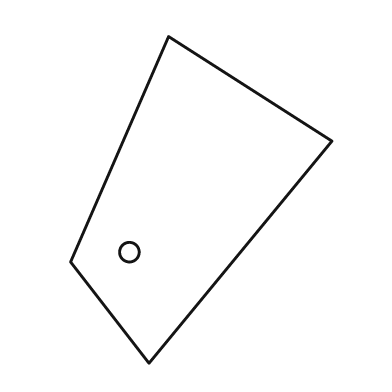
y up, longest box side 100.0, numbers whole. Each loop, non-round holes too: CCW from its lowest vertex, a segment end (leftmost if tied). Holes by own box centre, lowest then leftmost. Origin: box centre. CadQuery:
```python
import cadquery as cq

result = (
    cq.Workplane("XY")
    .moveTo(-16.0, -50.0)
    .lineTo(40.0, 18.0)
    .lineTo(-10.0, 50.0)
    .lineTo(-40.0, -19.0)
    .close()
    .moveTo(-22.0, -16.0)
    .circle(3.0)
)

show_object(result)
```